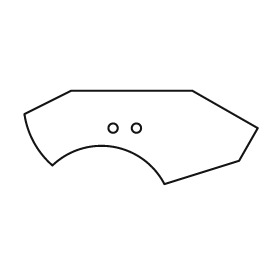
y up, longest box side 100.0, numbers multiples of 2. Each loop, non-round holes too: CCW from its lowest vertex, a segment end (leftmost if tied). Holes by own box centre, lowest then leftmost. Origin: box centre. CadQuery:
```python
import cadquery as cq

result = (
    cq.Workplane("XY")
    .moveTo(10.0, -20.0)
    .lineTo(42.0, -10.0)
    .lineTo(50.0, 4.0)
    .lineTo(22.0, 20.0)
    .lineTo(-30.0, 20.0)
    .lineTo(-50.0, 10.0)
    .threePointArc((-46.0, -2.0), (-38.0, -12.0))
    .threePointArc((-12.0, -4.0), (10.0, -20.0))
    .close()
    .moveTo(-12.0, 4.0)
    .circle(2.0)
    .moveTo(-2.0, 4.0)
    .circle(2.0)
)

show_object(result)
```